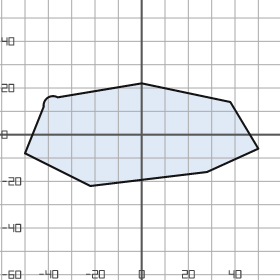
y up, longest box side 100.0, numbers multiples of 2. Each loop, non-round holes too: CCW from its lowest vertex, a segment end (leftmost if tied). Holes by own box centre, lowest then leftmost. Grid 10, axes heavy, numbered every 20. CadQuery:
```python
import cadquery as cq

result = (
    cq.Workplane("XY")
    .moveTo(-22.0, -22.0)
    .lineTo(28.0, -16.0)
    .lineTo(50.0, -6.0)
    .lineTo(38.0, 14.0)
    .lineTo(0.0, 22.0)
    .lineTo(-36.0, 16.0)
    .threePointArc((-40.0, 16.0), (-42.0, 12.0))
    .lineTo(-50.0, -8.0)
    .close()
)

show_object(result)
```